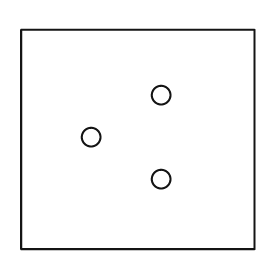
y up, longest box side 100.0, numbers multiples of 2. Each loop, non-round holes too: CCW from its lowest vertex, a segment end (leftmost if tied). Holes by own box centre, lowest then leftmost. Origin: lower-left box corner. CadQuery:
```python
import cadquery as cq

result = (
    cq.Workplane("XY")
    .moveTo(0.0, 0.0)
    .lineTo(100.0, 0.0)
    .lineTo(100.0, 94.0)
    .lineTo(0.0, 94.0)
    .close()
    .moveTo(60.0, 30.0)
    .circle(4.0)
    .moveTo(30.0, 48.0)
    .circle(4.0)
    .moveTo(60.0, 66.0)
    .circle(4.0)
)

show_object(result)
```